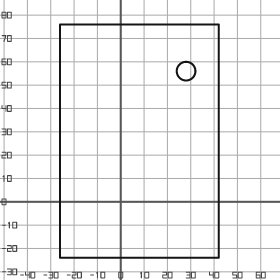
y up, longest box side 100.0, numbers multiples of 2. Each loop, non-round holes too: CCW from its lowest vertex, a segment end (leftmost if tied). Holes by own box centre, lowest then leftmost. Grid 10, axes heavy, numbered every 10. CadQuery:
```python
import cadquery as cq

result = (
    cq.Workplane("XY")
    .moveTo(-26.0, -24.0)
    .lineTo(42.0, -24.0)
    .lineTo(42.0, 76.0)
    .lineTo(-26.0, 76.0)
    .close()
    .moveTo(28.0, 56.0)
    .circle(4.0)
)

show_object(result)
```